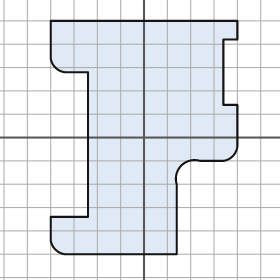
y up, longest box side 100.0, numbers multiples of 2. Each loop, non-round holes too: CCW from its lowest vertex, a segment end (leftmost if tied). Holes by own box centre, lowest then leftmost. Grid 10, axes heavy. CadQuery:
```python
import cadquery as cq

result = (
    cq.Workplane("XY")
    .moveTo(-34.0, -50.0)
    .lineTo(14.0, -50.0)
    .lineTo(14.0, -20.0)
    .threePointArc((16.0, -12.0), (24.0, -10.0))
    .lineTo(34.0, -10.0)
    .threePointArc((38.0, -8.0), (40.0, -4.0))
    .lineTo(40.0, 14.0)
    .lineTo(34.0, 14.0)
    .lineTo(34.0, 42.0)
    .lineTo(40.0, 42.0)
    .lineTo(40.0, 50.0)
    .lineTo(-40.0, 50.0)
    .lineTo(-40.0, 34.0)
    .threePointArc((-38.0, 30.0), (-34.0, 28.0))
    .lineTo(-24.0, 28.0)
    .lineTo(-24.0, -34.0)
    .lineTo(-40.0, -34.0)
    .lineTo(-40.0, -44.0)
    .threePointArc((-38.0, -48.0), (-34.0, -50.0))
    .close()
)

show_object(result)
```